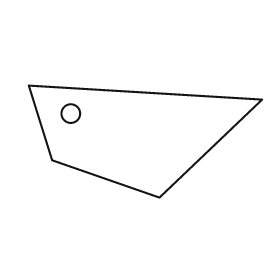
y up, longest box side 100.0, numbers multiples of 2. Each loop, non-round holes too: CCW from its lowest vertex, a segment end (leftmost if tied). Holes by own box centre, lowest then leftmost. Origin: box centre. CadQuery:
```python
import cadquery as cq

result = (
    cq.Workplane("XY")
    .moveTo(6.0, -24.0)
    .lineTo(50.0, 18.0)
    .lineTo(-50.0, 24.0)
    .lineTo(-40.0, -8.0)
    .close()
    .moveTo(-32.0, 12.0)
    .circle(4.0)
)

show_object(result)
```